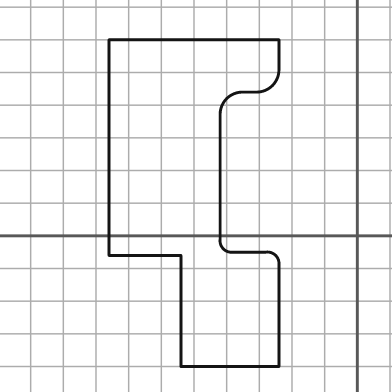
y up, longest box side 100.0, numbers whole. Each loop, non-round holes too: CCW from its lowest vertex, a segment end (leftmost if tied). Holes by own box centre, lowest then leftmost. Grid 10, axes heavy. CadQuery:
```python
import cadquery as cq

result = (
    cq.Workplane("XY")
    .moveTo(-54.0, -40.0)
    .lineTo(-24.0, -40.0)
    .lineTo(-24.0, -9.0)
    .threePointArc((-25.0, -6.0), (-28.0, -5.0))
    .lineTo(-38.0, -5.0)
    .threePointArc((-41.0, -4.0), (-42.0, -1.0))
    .lineTo(-42.0, 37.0)
    .threePointArc((-40.0, 42.0), (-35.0, 44.0))
    .lineTo(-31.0, 44.0)
    .threePointArc((-26.0, 46.0), (-24.0, 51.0))
    .lineTo(-24.0, 60.0)
    .lineTo(-76.0, 60.0)
    .lineTo(-76.0, -6.0)
    .lineTo(-54.0, -6.0)
    .close()
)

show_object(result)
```